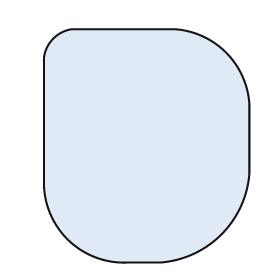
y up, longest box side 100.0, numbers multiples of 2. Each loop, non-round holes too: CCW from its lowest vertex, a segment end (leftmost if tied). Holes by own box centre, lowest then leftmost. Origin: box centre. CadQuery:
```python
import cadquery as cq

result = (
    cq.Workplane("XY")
    .moveTo(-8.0, -50.0)
    .lineTo(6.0, -50.0)
    .threePointArc((32.0, -38.0), (44.0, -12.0))
    .lineTo(44.0, 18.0)
    .threePointArc((34.0, 40.0), (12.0, 50.0))
    .lineTo(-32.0, 50.0)
    .threePointArc((-40.0, 46.0), (-44.0, 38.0))
    .lineTo(-44.0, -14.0)
    .threePointArc((-34.0, -40.0), (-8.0, -50.0))
    .close()
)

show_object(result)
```